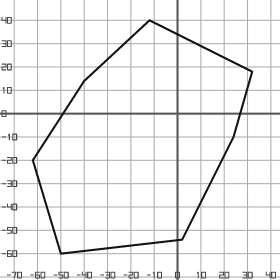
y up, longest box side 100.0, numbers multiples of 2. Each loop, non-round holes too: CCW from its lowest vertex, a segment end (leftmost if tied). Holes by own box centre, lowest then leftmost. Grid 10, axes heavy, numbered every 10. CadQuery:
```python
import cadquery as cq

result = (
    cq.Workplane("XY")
    .moveTo(-50.0, -60.0)
    .lineTo(2.0, -54.0)
    .lineTo(24.0, -10.0)
    .lineTo(32.0, 18.0)
    .lineTo(-12.0, 40.0)
    .lineTo(-40.0, 14.0)
    .lineTo(-62.0, -20.0)
    .close()
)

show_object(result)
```